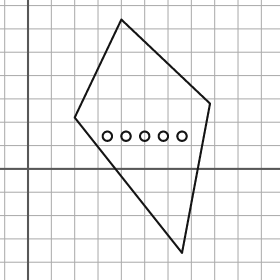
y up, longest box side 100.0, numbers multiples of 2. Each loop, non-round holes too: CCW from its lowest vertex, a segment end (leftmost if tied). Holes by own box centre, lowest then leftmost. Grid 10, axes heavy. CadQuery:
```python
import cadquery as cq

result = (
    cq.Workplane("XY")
    .moveTo(66.0, -36.0)
    .lineTo(78.0, 28.0)
    .lineTo(40.0, 64.0)
    .lineTo(20.0, 22.0)
    .close()
    .moveTo(34.0, 14.0)
    .circle(2.0)
    .moveTo(42.0, 14.0)
    .circle(2.0)
    .moveTo(50.0, 14.0)
    .circle(2.0)
    .moveTo(58.0, 14.0)
    .circle(2.0)
    .moveTo(66.0, 14.0)
    .circle(2.0)
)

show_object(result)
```